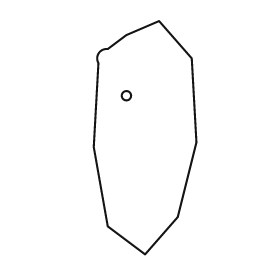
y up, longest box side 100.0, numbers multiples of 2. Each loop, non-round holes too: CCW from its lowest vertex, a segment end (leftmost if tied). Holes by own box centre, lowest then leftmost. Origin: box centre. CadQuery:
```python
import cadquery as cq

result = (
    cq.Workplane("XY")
    .moveTo(0.0, -50.0)
    .lineTo(14.0, -34.0)
    .lineTo(22.0, -2.0)
    .lineTo(20.0, 34.0)
    .lineTo(6.0, 50.0)
    .lineTo(-8.0, 44.0)
    .lineTo(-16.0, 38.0)
    .threePointArc((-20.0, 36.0), (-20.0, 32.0))
    .lineTo(-22.0, -4.0)
    .lineTo(-16.0, -38.0)
    .close()
    .moveTo(-8.0, 18.0)
    .circle(2.0)
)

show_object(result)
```